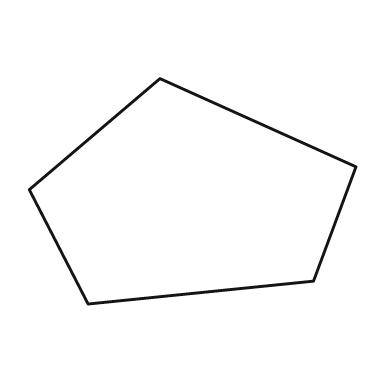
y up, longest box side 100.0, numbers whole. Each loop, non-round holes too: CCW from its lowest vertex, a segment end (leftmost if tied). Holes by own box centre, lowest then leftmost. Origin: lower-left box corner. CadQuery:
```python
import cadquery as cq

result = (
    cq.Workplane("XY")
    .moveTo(18.0, 0.0)
    .lineTo(87.0, 7.0)
    .lineTo(100.0, 42.0)
    .lineTo(40.0, 69.0)
    .lineTo(0.0, 35.0)
    .close()
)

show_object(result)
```